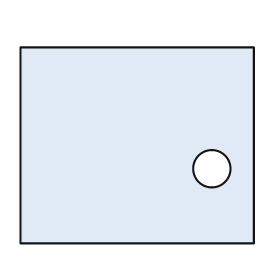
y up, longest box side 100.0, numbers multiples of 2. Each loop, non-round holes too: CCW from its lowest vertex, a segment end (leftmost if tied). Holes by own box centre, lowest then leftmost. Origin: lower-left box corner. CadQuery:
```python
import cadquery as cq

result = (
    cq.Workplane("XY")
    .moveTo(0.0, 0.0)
    .lineTo(100.0, 0.0)
    .lineTo(100.0, 84.0)
    .lineTo(0.0, 84.0)
    .close()
    .moveTo(82.0, 32.0)
    .circle(8.0)
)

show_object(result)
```